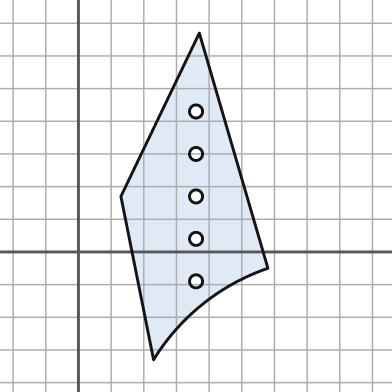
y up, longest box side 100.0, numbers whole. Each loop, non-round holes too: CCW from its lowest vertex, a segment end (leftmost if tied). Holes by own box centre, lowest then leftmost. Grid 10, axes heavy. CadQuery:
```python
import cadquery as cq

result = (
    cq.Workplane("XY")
    .moveTo(23.0, -33.0)
    .threePointArc((38.0, -16.0), (58.0, -5.0))
    .lineTo(37.0, 67.0)
    .lineTo(13.0, 17.0)
    .close()
    .moveTo(36.0, -9.0)
    .circle(2.0)
    .moveTo(36.0, 4.0)
    .circle(2.0)
    .moveTo(36.0, 17.0)
    .circle(2.0)
    .moveTo(36.0, 30.0)
    .circle(2.0)
    .moveTo(36.0, 43.0)
    .circle(2.0)
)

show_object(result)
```